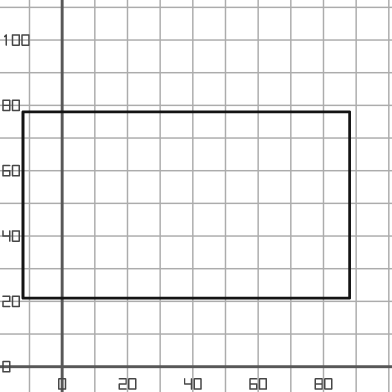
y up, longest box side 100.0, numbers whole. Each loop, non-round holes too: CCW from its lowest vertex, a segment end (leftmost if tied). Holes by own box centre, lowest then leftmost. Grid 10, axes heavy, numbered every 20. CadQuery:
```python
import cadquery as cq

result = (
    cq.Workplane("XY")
    .moveTo(-12.0, 21.0)
    .lineTo(88.0, 21.0)
    .lineTo(88.0, 78.0)
    .lineTo(-12.0, 78.0)
    .close()
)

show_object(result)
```